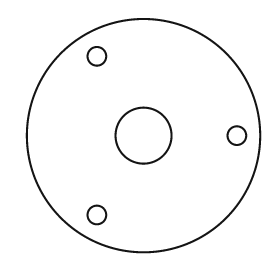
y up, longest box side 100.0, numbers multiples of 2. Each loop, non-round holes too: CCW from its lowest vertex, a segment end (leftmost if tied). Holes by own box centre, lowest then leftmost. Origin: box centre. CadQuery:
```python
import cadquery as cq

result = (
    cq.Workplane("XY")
    .moveTo(0.0, 0.0)
    .circle(50.0)
    .moveTo(-20.0, -34.0)
    .circle(4.0)
    .moveTo(0.0, 0.0)
    .circle(12.0)
    .moveTo(40.0, 0.0)
    .circle(4.0)
    .moveTo(-20.0, 34.0)
    .circle(4.0)
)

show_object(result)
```